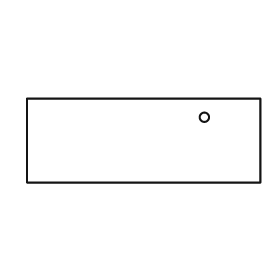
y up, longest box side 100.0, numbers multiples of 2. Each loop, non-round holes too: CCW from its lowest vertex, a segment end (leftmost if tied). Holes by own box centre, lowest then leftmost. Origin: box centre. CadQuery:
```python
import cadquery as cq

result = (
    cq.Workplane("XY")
    .moveTo(-50.0, -18.0)
    .lineTo(50.0, -18.0)
    .lineTo(50.0, 18.0)
    .lineTo(-50.0, 18.0)
    .close()
    .moveTo(26.0, 10.0)
    .circle(2.0)
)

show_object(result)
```